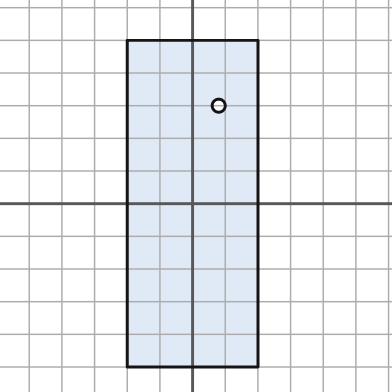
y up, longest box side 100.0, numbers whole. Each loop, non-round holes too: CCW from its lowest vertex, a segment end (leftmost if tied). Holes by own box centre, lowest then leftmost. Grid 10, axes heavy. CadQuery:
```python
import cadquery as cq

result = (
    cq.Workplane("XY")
    .moveTo(-20.0, -50.0)
    .lineTo(20.0, -50.0)
    .lineTo(20.0, 50.0)
    .lineTo(-20.0, 50.0)
    .close()
    .moveTo(8.0, 30.0)
    .circle(2.0)
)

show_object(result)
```